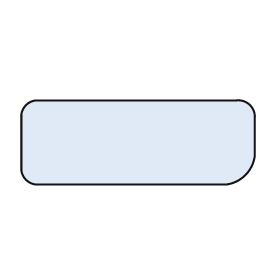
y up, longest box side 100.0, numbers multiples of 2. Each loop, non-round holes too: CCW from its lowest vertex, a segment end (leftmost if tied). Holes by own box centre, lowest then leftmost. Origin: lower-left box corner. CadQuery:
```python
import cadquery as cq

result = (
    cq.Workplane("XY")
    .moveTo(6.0, 0.0)
    .lineTo(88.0, 0.0)
    .threePointArc((96.0, 4.0), (100.0, 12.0))
    .lineTo(100.0, 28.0)
    .threePointArc((98.0, 34.0), (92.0, 36.0))
    .lineTo(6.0, 36.0)
    .threePointArc((2.0, 34.0), (0.0, 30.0))
    .lineTo(0.0, 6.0)
    .threePointArc((2.0, 2.0), (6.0, 0.0))
    .close()
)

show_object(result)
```